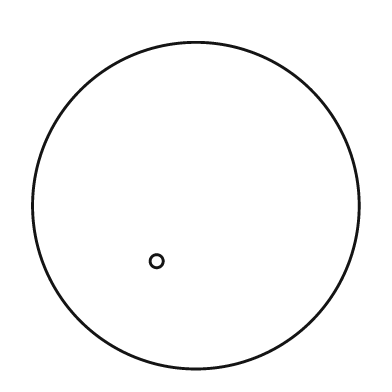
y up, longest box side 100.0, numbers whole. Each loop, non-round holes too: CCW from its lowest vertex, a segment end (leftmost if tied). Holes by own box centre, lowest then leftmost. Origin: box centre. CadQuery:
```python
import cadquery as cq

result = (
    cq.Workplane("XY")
    .moveTo(0.0, 0.0)
    .circle(50.0)
    .moveTo(-12.0, -17.0)
    .circle(2.0)
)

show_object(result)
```